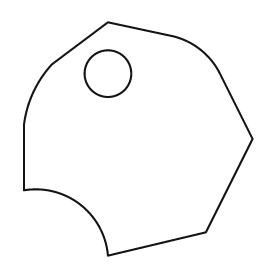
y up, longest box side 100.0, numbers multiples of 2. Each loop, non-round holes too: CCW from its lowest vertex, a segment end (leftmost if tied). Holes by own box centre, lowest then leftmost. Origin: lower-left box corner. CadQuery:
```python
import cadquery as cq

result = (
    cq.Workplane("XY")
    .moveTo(36.0, 0.0)
    .lineTo(78.0, 10.0)
    .lineTo(98.0, 50.0)
    .lineTo(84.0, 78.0)
    .threePointArc((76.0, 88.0), (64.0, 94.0))
    .lineTo(36.0, 100.0)
    .lineTo(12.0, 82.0)
    .threePointArc((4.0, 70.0), (0.0, 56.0))
    .lineTo(0.0, 28.0)
    .threePointArc((24.0, 22.0), (36.0, 0.0))
    .close()
    .moveTo(36.0, 78.0)
    .circle(10.0)
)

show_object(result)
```